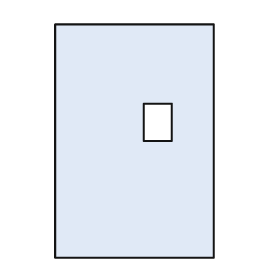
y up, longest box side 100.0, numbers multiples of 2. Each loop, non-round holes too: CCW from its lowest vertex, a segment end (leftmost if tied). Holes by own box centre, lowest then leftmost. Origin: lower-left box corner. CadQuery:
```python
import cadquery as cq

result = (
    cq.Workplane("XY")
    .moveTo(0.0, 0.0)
    .lineTo(68.0, 0.0)
    .lineTo(68.0, 100.0)
    .lineTo(0.0, 100.0)
    .close()
    .moveTo(38.0, 50.0)
    .lineTo(50.0, 50.0)
    .lineTo(50.0, 66.0)
    .lineTo(38.0, 66.0)
    .close()
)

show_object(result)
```